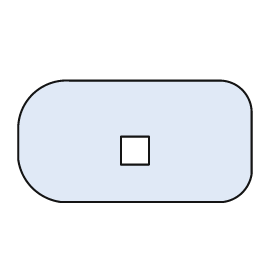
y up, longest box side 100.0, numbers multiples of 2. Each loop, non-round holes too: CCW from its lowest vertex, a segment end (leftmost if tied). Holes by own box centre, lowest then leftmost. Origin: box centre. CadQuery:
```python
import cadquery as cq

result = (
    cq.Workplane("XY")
    .moveTo(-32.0, -26.0)
    .lineTo(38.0, -26.0)
    .threePointArc((46.0, -22.0), (50.0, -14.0))
    .lineTo(50.0, 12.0)
    .threePointArc((46.0, 22.0), (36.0, 26.0))
    .lineTo(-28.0, 26.0)
    .threePointArc((-44.0, 20.0), (-50.0, 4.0))
    .lineTo(-50.0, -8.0)
    .threePointArc((-44.0, -20.0), (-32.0, -26.0))
    .close()
    .moveTo(-6.0, -10.0)
    .lineTo(6.0, -10.0)
    .lineTo(6.0, 2.0)
    .lineTo(-6.0, 2.0)
    .close()
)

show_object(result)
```